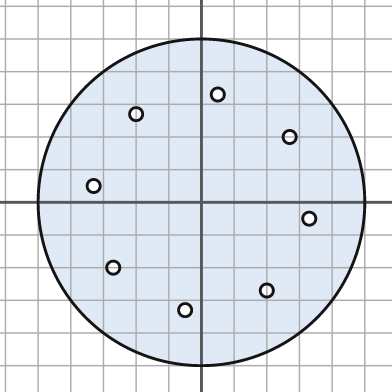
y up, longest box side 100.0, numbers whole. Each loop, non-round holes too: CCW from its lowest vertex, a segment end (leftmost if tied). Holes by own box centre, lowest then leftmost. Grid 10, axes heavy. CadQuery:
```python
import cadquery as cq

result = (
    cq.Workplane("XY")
    .moveTo(0.0, 0.0)
    .circle(50.0)
    .moveTo(-5.0, -33.0)
    .circle(2.0)
    .moveTo(20.0, -27.0)
    .circle(2.0)
    .moveTo(-27.0, -20.0)
    .circle(2.0)
    .moveTo(33.0, -5.0)
    .circle(2.0)
    .moveTo(-33.0, 5.0)
    .circle(2.0)
    .moveTo(27.0, 20.0)
    .circle(2.0)
    .moveTo(-20.0, 27.0)
    .circle(2.0)
    .moveTo(5.0, 33.0)
    .circle(2.0)
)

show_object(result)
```